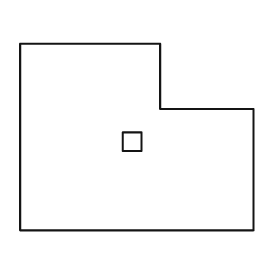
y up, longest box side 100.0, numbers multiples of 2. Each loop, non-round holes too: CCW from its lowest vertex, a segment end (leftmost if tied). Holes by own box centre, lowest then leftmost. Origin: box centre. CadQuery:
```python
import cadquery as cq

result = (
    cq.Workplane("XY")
    .moveTo(-50.0, -40.0)
    .lineTo(50.0, -40.0)
    .lineTo(50.0, 12.0)
    .lineTo(10.0, 12.0)
    .lineTo(10.0, 40.0)
    .lineTo(-50.0, 40.0)
    .close()
    .moveTo(-6.0, -6.0)
    .lineTo(2.0, -6.0)
    .lineTo(2.0, 2.0)
    .lineTo(-6.0, 2.0)
    .close()
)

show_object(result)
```